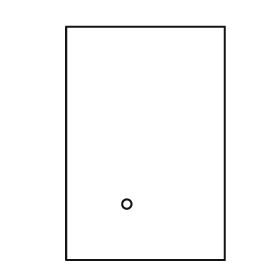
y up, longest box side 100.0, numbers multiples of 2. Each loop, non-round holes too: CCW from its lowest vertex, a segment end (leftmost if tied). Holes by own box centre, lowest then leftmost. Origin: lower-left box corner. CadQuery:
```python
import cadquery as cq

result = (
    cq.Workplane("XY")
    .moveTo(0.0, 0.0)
    .lineTo(68.0, 0.0)
    .lineTo(68.0, 100.0)
    .lineTo(0.0, 100.0)
    .close()
    .moveTo(26.0, 24.0)
    .circle(2.0)
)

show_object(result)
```